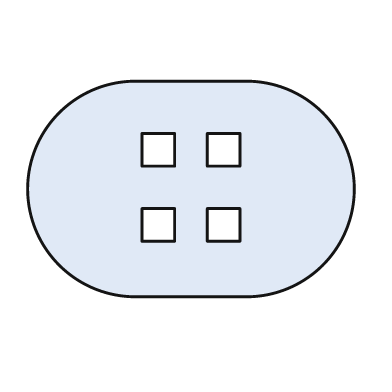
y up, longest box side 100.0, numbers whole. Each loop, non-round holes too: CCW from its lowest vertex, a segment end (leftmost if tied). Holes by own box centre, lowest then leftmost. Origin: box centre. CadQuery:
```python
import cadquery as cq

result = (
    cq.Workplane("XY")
    .moveTo(-17.0, -33.0)
    .lineTo(17.0, -33.0)
    .threePointArc((50.0, 0.0), (17.0, 33.0))
    .lineTo(-17.0, 33.0)
    .threePointArc((-50.0, 0.0), (-17.0, -33.0))
    .close()
    .moveTo(-15.0, -16.0)
    .lineTo(-5.0, -16.0)
    .lineTo(-5.0, -6.0)
    .lineTo(-15.0, -6.0)
    .close()
    .moveTo(5.0, -16.0)
    .lineTo(15.0, -16.0)
    .lineTo(15.0, -6.0)
    .lineTo(5.0, -6.0)
    .close()
    .moveTo(-15.0, 7.0)
    .lineTo(-5.0, 7.0)
    .lineTo(-5.0, 17.0)
    .lineTo(-15.0, 17.0)
    .close()
    .moveTo(5.0, 7.0)
    .lineTo(15.0, 7.0)
    .lineTo(15.0, 17.0)
    .lineTo(5.0, 17.0)
    .close()
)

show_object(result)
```